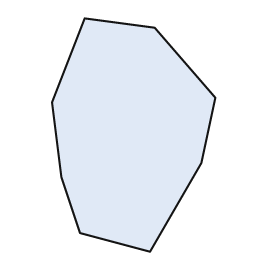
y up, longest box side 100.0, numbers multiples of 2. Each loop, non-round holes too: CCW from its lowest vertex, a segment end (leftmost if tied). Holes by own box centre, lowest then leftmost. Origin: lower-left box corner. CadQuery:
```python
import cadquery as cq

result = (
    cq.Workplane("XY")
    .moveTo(42.0, 0.0)
    .lineTo(64.0, 38.0)
    .lineTo(70.0, 66.0)
    .lineTo(44.0, 96.0)
    .lineTo(14.0, 100.0)
    .lineTo(0.0, 64.0)
    .lineTo(4.0, 32.0)
    .lineTo(12.0, 8.0)
    .close()
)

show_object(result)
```